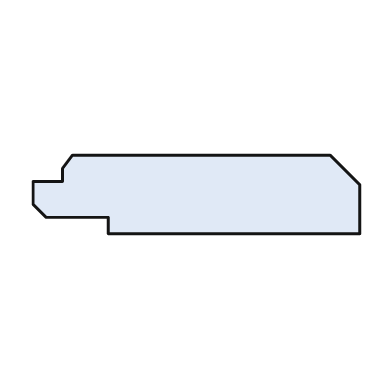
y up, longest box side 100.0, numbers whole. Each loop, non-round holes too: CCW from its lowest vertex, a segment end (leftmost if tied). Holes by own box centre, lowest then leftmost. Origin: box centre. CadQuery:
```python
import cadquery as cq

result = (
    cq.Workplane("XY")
    .moveTo(-27.0, -12.0)
    .lineTo(50.0, -12.0)
    .lineTo(50.0, 3.0)
    .lineTo(41.0, 12.0)
    .lineTo(-38.0, 12.0)
    .lineTo(-41.0, 8.0)
    .lineTo(-41.0, 4.0)
    .lineTo(-50.0, 4.0)
    .lineTo(-50.0, -3.0)
    .lineTo(-46.0, -7.0)
    .lineTo(-27.0, -7.0)
    .close()
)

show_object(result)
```